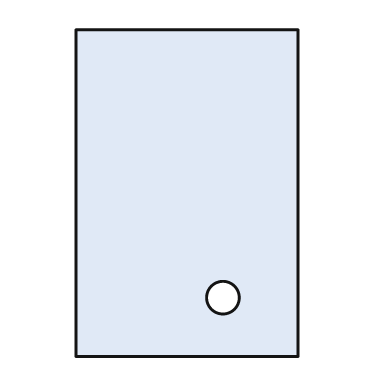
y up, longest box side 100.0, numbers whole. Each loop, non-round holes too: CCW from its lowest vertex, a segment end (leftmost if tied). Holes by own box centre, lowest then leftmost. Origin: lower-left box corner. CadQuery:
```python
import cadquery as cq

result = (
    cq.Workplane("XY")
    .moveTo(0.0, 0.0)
    .lineTo(68.0, 0.0)
    .lineTo(68.0, 100.0)
    .lineTo(0.0, 100.0)
    .close()
    .moveTo(45.0, 18.0)
    .circle(5.0)
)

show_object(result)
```